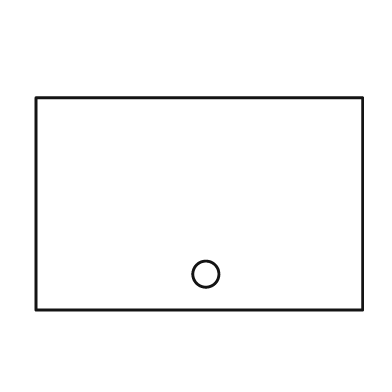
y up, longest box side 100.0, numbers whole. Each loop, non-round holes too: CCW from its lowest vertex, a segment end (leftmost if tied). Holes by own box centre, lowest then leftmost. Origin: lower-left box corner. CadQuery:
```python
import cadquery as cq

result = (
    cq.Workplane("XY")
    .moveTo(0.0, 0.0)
    .lineTo(100.0, 0.0)
    .lineTo(100.0, 65.0)
    .lineTo(0.0, 65.0)
    .close()
    .moveTo(52.0, 11.0)
    .circle(4.0)
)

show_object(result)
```